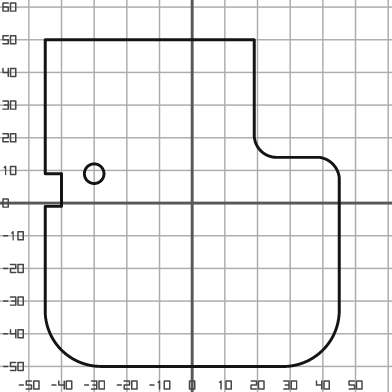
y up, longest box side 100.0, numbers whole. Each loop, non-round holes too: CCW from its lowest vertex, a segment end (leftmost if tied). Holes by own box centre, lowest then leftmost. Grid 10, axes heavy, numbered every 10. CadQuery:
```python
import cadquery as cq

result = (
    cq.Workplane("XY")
    .moveTo(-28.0, -50.0)
    .lineTo(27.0, -50.0)
    .threePointArc((40.0, -45.0), (45.0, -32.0))
    .lineTo(45.0, 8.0)
    .threePointArc((43.0, 12.0), (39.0, 14.0))
    .lineTo(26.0, 14.0)
    .threePointArc((21.0, 16.0), (19.0, 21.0))
    .lineTo(19.0, 50.0)
    .lineTo(-45.0, 50.0)
    .lineTo(-45.0, 9.0)
    .lineTo(-40.0, 9.0)
    .lineTo(-40.0, -1.0)
    .lineTo(-45.0, -1.0)
    .lineTo(-45.0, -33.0)
    .threePointArc((-40.0, -45.0), (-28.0, -50.0))
    .close()
    .moveTo(-30.0, 9.0)
    .circle(3.0)
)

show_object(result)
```